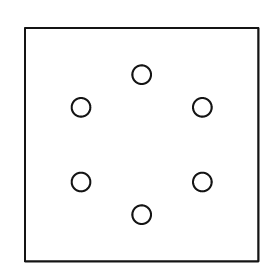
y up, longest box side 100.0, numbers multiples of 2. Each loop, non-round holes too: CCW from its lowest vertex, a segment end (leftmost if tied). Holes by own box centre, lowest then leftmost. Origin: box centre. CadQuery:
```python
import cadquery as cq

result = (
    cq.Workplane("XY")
    .moveTo(-50.0, -50.0)
    .lineTo(50.0, -50.0)
    .lineTo(50.0, 50.0)
    .lineTo(-50.0, 50.0)
    .close()
    .moveTo(0.0, -30.0)
    .circle(4.0)
    .moveTo(-26.0, -16.0)
    .circle(4.0)
    .moveTo(26.0, -16.0)
    .circle(4.0)
    .moveTo(-26.0, 16.0)
    .circle(4.0)
    .moveTo(26.0, 16.0)
    .circle(4.0)
    .moveTo(0.0, 30.0)
    .circle(4.0)
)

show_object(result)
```